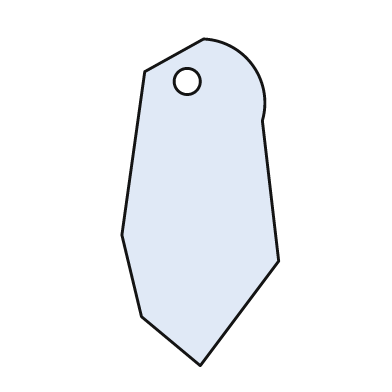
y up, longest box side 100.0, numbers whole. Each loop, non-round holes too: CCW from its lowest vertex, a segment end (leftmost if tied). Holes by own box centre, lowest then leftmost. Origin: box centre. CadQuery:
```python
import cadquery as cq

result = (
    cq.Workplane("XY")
    .moveTo(0.0, -50.0)
    .lineTo(24.0, -18.0)
    .lineTo(19.0, 25.0)
    .threePointArc((16.0, 42.0), (1.0, 50.0))
    .lineTo(-17.0, 40.0)
    .lineTo(-24.0, -10.0)
    .lineTo(-18.0, -35.0)
    .close()
    .moveTo(-4.0, 37.0)
    .circle(4.0)
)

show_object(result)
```